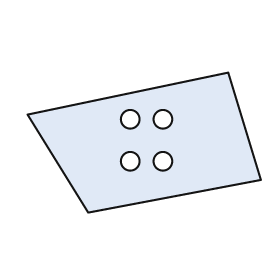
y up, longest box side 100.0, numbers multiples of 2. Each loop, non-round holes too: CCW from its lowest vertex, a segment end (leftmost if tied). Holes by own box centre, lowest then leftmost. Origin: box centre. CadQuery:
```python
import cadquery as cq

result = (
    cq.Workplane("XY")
    .moveTo(-24.0, -30.0)
    .lineTo(50.0, -16.0)
    .lineTo(36.0, 30.0)
    .lineTo(-50.0, 12.0)
    .close()
    .moveTo(-6.0, -8.0)
    .circle(4.0)
    .moveTo(8.0, -8.0)
    .circle(4.0)
    .moveTo(-6.0, 10.0)
    .circle(4.0)
    .moveTo(8.0, 10.0)
    .circle(4.0)
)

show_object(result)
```